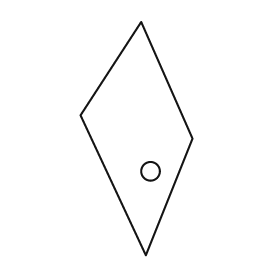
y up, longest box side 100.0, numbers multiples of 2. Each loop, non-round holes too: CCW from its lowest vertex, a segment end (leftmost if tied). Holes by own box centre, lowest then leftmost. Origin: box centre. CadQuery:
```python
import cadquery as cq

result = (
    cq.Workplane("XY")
    .moveTo(4.0, -50.0)
    .lineTo(24.0, 0.0)
    .lineTo(2.0, 50.0)
    .lineTo(-24.0, 10.0)
    .close()
    .moveTo(6.0, -14.0)
    .circle(4.0)
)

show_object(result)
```